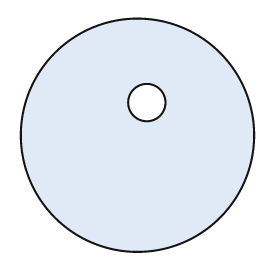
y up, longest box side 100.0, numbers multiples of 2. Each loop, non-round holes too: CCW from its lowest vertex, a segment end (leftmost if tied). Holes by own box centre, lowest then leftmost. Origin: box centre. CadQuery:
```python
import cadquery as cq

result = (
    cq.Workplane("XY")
    .moveTo(0.0, 0.0)
    .circle(50.0)
    .moveTo(4.0, 14.0)
    .circle(8.0)
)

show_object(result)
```